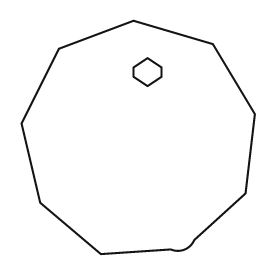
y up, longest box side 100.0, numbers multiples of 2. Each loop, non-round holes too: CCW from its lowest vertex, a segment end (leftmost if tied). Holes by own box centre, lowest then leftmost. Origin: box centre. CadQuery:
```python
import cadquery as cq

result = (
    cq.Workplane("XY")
    .moveTo(-16.0, -50.0)
    .lineTo(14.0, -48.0)
    .threePointArc((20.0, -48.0), (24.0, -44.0))
    .lineTo(46.0, -24.0)
    .lineTo(50.0, 10.0)
    .lineTo(32.0, 40.0)
    .lineTo(-2.0, 50.0)
    .lineTo(-34.0, 38.0)
    .lineTo(-50.0, 6.0)
    .lineTo(-42.0, -28.0)
    .close()
    .moveTo(4.0, 22.0)
    .lineTo(10.0, 26.0)
    .lineTo(10.0, 30.0)
    .lineTo(4.0, 34.0)
    .lineTo(-2.0, 30.0)
    .lineTo(-2.0, 26.0)
    .close()
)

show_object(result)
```